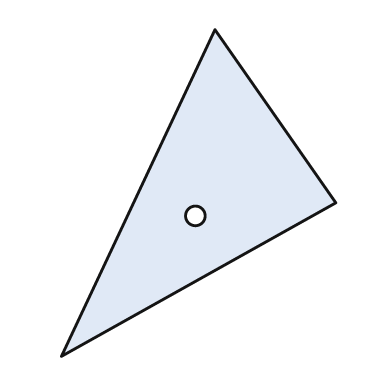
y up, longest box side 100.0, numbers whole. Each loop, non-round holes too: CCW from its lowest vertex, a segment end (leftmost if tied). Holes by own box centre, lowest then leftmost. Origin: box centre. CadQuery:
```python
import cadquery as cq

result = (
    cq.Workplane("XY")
    .moveTo(-42.0, -50.0)
    .lineTo(42.0, -3.0)
    .lineTo(5.0, 50.0)
    .close()
    .moveTo(-1.0, -7.0)
    .circle(3.0)
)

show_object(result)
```